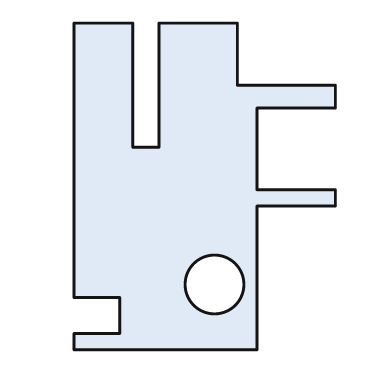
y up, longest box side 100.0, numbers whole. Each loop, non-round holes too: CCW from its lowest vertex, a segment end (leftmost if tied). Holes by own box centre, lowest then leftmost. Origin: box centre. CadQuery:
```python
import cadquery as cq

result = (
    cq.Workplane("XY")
    .moveTo(-40.0, -50.0)
    .lineTo(16.0, -50.0)
    .lineTo(16.0, -6.0)
    .lineTo(40.0, -6.0)
    .lineTo(40.0, -1.0)
    .lineTo(16.0, -1.0)
    .lineTo(16.0, 24.0)
    .lineTo(40.0, 24.0)
    .lineTo(40.0, 31.0)
    .lineTo(10.0, 31.0)
    .lineTo(10.0, 50.0)
    .lineTo(-14.0, 50.0)
    .lineTo(-14.0, 12.0)
    .lineTo(-22.0, 12.0)
    .lineTo(-22.0, 50.0)
    .lineTo(-40.0, 50.0)
    .lineTo(-40.0, -34.0)
    .lineTo(-26.0, -34.0)
    .lineTo(-26.0, -45.0)
    .lineTo(-40.0, -45.0)
    .close()
    .moveTo(3.0, -30.0)
    .circle(9.0)
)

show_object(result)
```